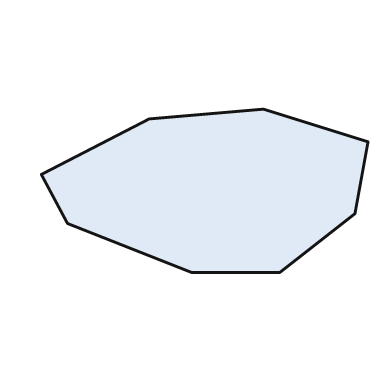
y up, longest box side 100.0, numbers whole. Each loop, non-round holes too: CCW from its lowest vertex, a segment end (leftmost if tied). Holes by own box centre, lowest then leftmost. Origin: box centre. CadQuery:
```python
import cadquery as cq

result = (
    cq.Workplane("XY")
    .moveTo(-4.0, -25.0)
    .lineTo(23.0, -25.0)
    .lineTo(46.0, -7.0)
    .lineTo(50.0, 15.0)
    .lineTo(18.0, 25.0)
    .lineTo(-17.0, 22.0)
    .lineTo(-50.0, 5.0)
    .lineTo(-42.0, -10.0)
    .close()
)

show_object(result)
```